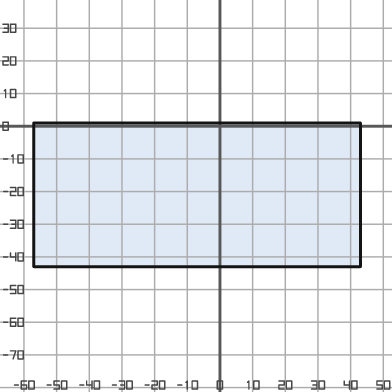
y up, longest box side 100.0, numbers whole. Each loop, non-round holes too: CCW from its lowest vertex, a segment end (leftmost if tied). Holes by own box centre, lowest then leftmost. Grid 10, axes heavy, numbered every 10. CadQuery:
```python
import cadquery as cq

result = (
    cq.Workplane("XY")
    .moveTo(-57.0, -43.0)
    .lineTo(43.0, -43.0)
    .lineTo(43.0, 1.0)
    .lineTo(-57.0, 1.0)
    .close()
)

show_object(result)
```